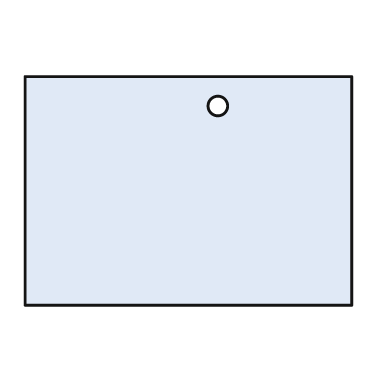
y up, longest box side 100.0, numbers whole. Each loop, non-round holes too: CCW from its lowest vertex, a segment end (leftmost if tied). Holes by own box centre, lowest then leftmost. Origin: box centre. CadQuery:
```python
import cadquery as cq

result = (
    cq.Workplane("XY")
    .moveTo(-50.0, -35.0)
    .lineTo(50.0, -35.0)
    .lineTo(50.0, 35.0)
    .lineTo(-50.0, 35.0)
    .close()
    .moveTo(9.0, 26.0)
    .circle(3.0)
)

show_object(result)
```